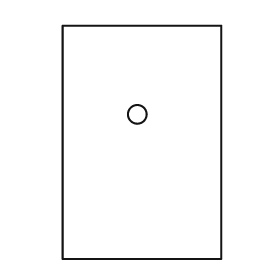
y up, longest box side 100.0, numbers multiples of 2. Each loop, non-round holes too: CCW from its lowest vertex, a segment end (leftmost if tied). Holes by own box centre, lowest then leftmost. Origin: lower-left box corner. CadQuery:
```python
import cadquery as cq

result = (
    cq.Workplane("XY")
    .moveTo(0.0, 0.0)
    .lineTo(68.0, 0.0)
    .lineTo(68.0, 100.0)
    .lineTo(0.0, 100.0)
    .close()
    .moveTo(32.0, 62.0)
    .circle(4.0)
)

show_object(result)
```